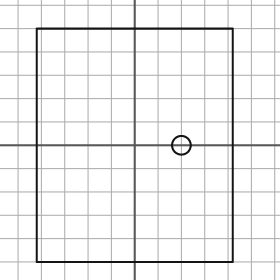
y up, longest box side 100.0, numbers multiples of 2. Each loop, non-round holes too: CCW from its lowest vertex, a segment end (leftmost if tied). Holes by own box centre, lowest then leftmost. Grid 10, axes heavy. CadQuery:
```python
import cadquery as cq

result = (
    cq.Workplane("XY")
    .moveTo(-42.0, -50.0)
    .lineTo(42.0, -50.0)
    .lineTo(42.0, 50.0)
    .lineTo(-42.0, 50.0)
    .close()
    .moveTo(20.0, 0.0)
    .circle(4.0)
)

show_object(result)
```